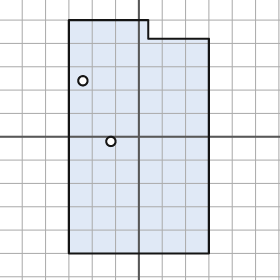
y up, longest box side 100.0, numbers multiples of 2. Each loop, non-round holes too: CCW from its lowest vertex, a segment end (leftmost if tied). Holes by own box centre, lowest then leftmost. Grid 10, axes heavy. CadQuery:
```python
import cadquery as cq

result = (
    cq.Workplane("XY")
    .moveTo(-30.0, -50.0)
    .lineTo(30.0, -50.0)
    .lineTo(30.0, 42.0)
    .lineTo(4.0, 42.0)
    .lineTo(4.0, 50.0)
    .lineTo(-30.0, 50.0)
    .close()
    .moveTo(-12.0, -2.0)
    .circle(2.0)
    .moveTo(-24.0, 24.0)
    .circle(2.0)
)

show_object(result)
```